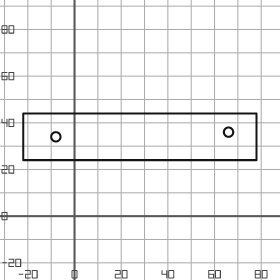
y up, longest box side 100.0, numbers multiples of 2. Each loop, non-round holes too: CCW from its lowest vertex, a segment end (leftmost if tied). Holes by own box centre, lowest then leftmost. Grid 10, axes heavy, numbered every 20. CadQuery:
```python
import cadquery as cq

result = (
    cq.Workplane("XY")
    .moveTo(-22.0, 24.0)
    .lineTo(78.0, 24.0)
    .lineTo(78.0, 44.0)
    .lineTo(-22.0, 44.0)
    .close()
    .moveTo(-8.0, 34.0)
    .circle(2.0)
    .moveTo(66.0, 36.0)
    .circle(2.0)
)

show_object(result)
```